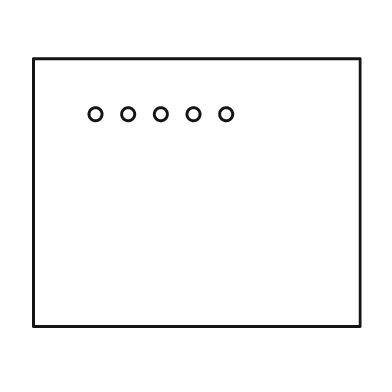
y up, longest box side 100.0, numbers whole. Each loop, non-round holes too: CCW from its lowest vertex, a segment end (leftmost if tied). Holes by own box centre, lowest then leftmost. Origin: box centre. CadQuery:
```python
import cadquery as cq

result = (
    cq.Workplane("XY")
    .moveTo(-50.0, -41.0)
    .lineTo(50.0, -41.0)
    .lineTo(50.0, 41.0)
    .lineTo(-50.0, 41.0)
    .close()
    .moveTo(-31.0, 24.0)
    .circle(2.0)
    .moveTo(-21.0, 24.0)
    .circle(2.0)
    .moveTo(-11.0, 24.0)
    .circle(2.0)
    .moveTo(-1.0, 24.0)
    .circle(2.0)
    .moveTo(9.0, 24.0)
    .circle(2.0)
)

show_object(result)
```